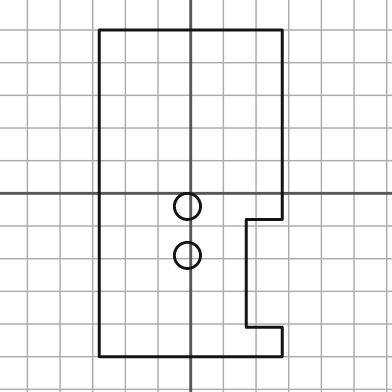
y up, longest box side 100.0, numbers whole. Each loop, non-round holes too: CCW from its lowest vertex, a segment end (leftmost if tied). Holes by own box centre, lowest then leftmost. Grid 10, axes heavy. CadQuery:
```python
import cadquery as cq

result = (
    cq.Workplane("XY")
    .moveTo(-28.0, -50.0)
    .lineTo(28.0, -50.0)
    .lineTo(28.0, -41.0)
    .lineTo(17.0, -41.0)
    .lineTo(17.0, -8.0)
    .lineTo(28.0, -8.0)
    .lineTo(28.0, 50.0)
    .lineTo(-28.0, 50.0)
    .close()
    .moveTo(-1.0, -19.0)
    .circle(4.0)
    .moveTo(-1.0, -4.0)
    .circle(4.0)
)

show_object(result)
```